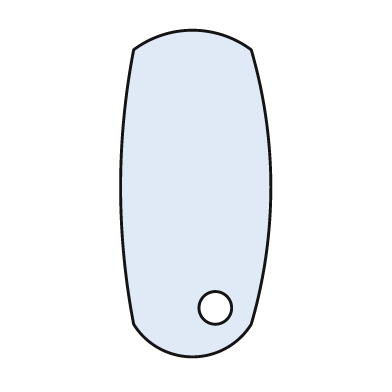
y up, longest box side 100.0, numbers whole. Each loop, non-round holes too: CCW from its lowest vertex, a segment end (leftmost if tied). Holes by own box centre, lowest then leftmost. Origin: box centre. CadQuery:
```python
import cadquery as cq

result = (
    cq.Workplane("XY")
    .moveTo(-19.0, -40.0)
    .threePointArc((-1.0, -50.0), (17.0, -40.0))
    .threePointArc((23.0, 2.0), (17.0, 44.0))
    .threePointArc((-1.0, 50.0), (-19.0, 44.0))
    .threePointArc((-23.0, 2.0), (-19.0, -40.0))
    .close()
    .moveTo(6.0, -35.0)
    .circle(5.0)
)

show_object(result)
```